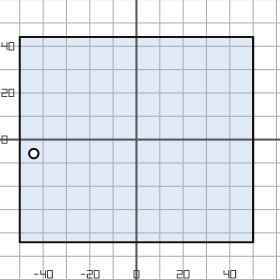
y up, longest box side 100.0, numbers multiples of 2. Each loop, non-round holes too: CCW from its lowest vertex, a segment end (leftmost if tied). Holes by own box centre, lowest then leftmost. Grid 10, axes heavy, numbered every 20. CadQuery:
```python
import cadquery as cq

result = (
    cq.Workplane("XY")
    .moveTo(-50.0, -44.0)
    .lineTo(50.0, -44.0)
    .lineTo(50.0, 44.0)
    .lineTo(-50.0, 44.0)
    .close()
    .moveTo(-44.0, -6.0)
    .circle(2.0)
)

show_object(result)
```